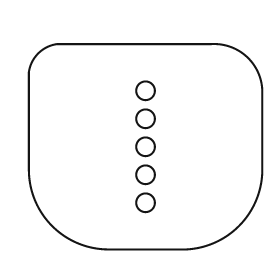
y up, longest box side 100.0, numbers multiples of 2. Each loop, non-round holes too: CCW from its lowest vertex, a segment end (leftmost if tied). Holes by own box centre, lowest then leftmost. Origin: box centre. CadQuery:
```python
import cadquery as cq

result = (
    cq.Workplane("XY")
    .moveTo(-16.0, -44.0)
    .lineTo(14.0, -44.0)
    .threePointArc((40.0, -34.0), (50.0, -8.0))
    .lineTo(50.0, 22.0)
    .threePointArc((44.0, 38.0), (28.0, 44.0))
    .lineTo(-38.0, 44.0)
    .threePointArc((-46.0, 40.0), (-50.0, 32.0))
    .lineTo(-50.0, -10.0)
    .threePointArc((-40.0, -34.0), (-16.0, -44.0))
    .close()
    .moveTo(0.0, -24.0)
    .circle(4.0)
    .moveTo(0.0, -12.0)
    .circle(4.0)
    .moveTo(0.0, 0.0)
    .circle(4.0)
    .moveTo(0.0, 12.0)
    .circle(4.0)
    .moveTo(0.0, 24.0)
    .circle(4.0)
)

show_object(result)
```